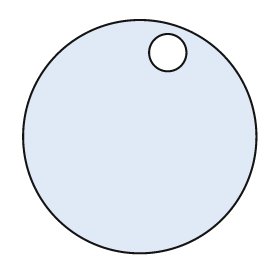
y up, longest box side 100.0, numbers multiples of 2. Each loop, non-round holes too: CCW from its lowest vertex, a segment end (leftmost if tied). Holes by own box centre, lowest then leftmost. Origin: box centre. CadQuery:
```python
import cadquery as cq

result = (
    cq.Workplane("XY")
    .moveTo(0.0, 0.0)
    .circle(50.0)
    .moveTo(12.0, 36.0)
    .circle(8.0)
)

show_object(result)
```